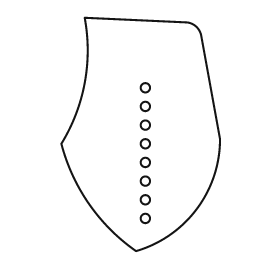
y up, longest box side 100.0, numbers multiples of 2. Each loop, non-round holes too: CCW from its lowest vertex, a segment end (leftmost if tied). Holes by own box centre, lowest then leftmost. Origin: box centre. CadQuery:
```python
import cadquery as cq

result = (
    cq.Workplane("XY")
    .moveTo(-2.0, -50.0)
    .threePointArc((24.0, -32.0), (34.0, -2.0))
    .lineTo(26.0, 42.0)
    .threePointArc((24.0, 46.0), (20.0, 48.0))
    .lineTo(-24.0, 50.0)
    .threePointArc((-24.0, 22.0), (-34.0, -4.0))
    .threePointArc((-22.0, -30.0), (-2.0, -50.0))
    .close()
    .moveTo(2.0, -36.0)
    .circle(2.0)
    .moveTo(2.0, -28.0)
    .circle(2.0)
    .moveTo(2.0, -20.0)
    .circle(2.0)
    .moveTo(2.0, -12.0)
    .circle(2.0)
    .moveTo(2.0, -4.0)
    .circle(2.0)
    .moveTo(2.0, 4.0)
    .circle(2.0)
    .moveTo(2.0, 12.0)
    .circle(2.0)
    .moveTo(2.0, 20.0)
    .circle(2.0)
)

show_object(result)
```